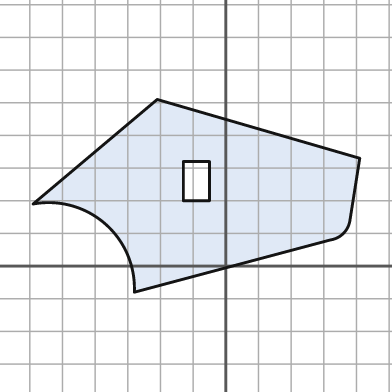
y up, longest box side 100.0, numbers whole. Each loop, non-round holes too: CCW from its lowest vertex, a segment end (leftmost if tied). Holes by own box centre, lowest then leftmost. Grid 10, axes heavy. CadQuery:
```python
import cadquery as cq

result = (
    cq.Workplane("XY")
    .moveTo(-28.0, -8.0)
    .lineTo(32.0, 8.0)
    .threePointArc((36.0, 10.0), (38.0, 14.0))
    .lineTo(41.0, 33.0)
    .lineTo(-21.0, 51.0)
    .lineTo(-59.0, 19.0)
    .threePointArc((-37.0, 13.0), (-28.0, -8.0))
    .close()
    .moveTo(-13.0, 20.0)
    .lineTo(-5.0, 20.0)
    .lineTo(-5.0, 32.0)
    .lineTo(-13.0, 32.0)
    .close()
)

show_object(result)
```